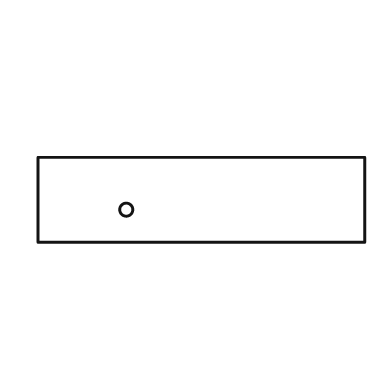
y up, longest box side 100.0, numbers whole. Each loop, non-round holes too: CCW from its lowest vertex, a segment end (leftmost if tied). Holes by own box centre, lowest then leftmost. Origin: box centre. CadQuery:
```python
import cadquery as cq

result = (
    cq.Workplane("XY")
    .moveTo(-50.0, -13.0)
    .lineTo(50.0, -13.0)
    .lineTo(50.0, 13.0)
    .lineTo(-50.0, 13.0)
    .close()
    .moveTo(-23.0, -3.0)
    .circle(2.0)
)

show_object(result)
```